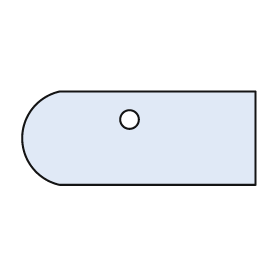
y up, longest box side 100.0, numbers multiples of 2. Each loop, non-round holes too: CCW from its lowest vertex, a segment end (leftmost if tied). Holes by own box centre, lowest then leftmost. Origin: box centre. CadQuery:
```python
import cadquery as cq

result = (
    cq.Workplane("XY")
    .moveTo(-34.0, -20.0)
    .lineTo(50.0, -20.0)
    .lineTo(50.0, 20.0)
    .lineTo(-34.0, 20.0)
    .threePointArc((-50.0, 0.0), (-34.0, -20.0))
    .close()
    .moveTo(-4.0, 8.0)
    .circle(4.0)
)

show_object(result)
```